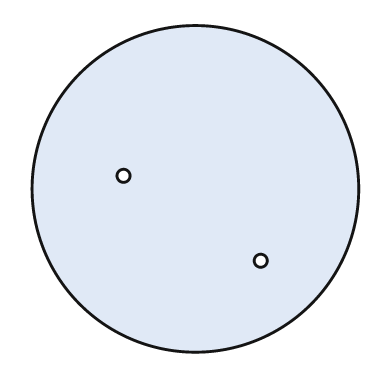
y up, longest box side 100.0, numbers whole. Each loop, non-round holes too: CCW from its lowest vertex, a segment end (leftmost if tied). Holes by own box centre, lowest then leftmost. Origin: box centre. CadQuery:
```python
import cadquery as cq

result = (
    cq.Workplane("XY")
    .moveTo(0.0, 0.0)
    .circle(50.0)
    .moveTo(20.0, -22.0)
    .circle(2.0)
    .moveTo(-22.0, 4.0)
    .circle(2.0)
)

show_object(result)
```